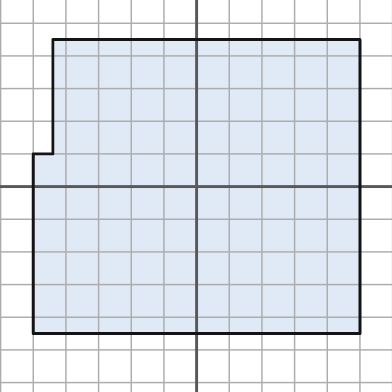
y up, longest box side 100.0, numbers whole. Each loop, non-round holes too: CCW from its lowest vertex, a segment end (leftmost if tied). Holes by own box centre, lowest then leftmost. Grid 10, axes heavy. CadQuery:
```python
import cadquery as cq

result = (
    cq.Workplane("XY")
    .moveTo(-50.0, -45.0)
    .lineTo(50.0, -45.0)
    .lineTo(50.0, 45.0)
    .lineTo(-44.0, 45.0)
    .lineTo(-44.0, 10.0)
    .lineTo(-50.0, 10.0)
    .close()
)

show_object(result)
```